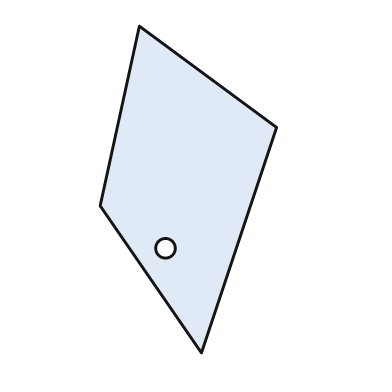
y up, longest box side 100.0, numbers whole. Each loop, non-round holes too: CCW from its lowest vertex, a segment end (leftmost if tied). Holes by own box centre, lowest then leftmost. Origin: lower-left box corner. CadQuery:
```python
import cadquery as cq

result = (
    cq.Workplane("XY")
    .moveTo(31.0, 0.0)
    .lineTo(54.0, 69.0)
    .lineTo(12.0, 100.0)
    .lineTo(0.0, 45.0)
    .close()
    .moveTo(20.0, 32.0)
    .circle(3.0)
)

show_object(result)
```